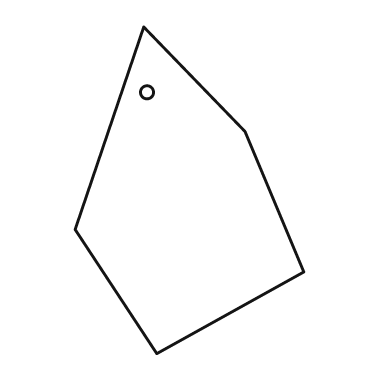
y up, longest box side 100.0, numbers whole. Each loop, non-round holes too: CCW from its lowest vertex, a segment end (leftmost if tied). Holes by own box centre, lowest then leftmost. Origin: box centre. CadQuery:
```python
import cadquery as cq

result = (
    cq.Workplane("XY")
    .moveTo(-10.0, -50.0)
    .lineTo(35.0, -25.0)
    .lineTo(17.0, 18.0)
    .lineTo(-14.0, 50.0)
    .lineTo(-35.0, -12.0)
    .close()
    .moveTo(-13.0, 30.0)
    .circle(2.0)
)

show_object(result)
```